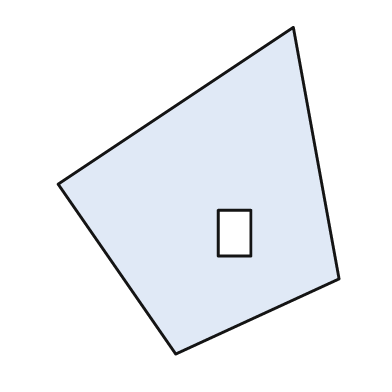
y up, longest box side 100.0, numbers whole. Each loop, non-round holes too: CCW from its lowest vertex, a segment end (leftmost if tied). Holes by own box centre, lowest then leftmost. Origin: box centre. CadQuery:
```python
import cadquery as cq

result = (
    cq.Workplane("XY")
    .moveTo(-7.0, -50.0)
    .lineTo(43.0, -27.0)
    .lineTo(29.0, 50.0)
    .lineTo(-43.0, 2.0)
    .close()
    .moveTo(6.0, -20.0)
    .lineTo(16.0, -20.0)
    .lineTo(16.0, -6.0)
    .lineTo(6.0, -6.0)
    .close()
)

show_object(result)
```